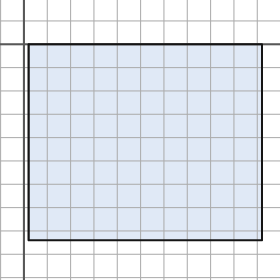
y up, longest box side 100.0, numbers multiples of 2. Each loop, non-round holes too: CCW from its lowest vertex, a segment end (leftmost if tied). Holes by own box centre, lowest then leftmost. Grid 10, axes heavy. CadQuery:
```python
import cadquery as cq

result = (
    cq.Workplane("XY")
    .moveTo(2.0, -84.0)
    .lineTo(102.0, -84.0)
    .lineTo(102.0, 0.0)
    .lineTo(2.0, 0.0)
    .close()
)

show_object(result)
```